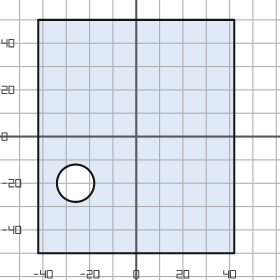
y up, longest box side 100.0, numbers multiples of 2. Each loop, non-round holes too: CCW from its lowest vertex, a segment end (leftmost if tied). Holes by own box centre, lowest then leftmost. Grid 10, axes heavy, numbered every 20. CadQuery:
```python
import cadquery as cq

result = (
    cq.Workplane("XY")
    .moveTo(-42.0, -50.0)
    .lineTo(42.0, -50.0)
    .lineTo(42.0, 50.0)
    .lineTo(-42.0, 50.0)
    .close()
    .moveTo(-26.0, -20.0)
    .circle(8.0)
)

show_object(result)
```